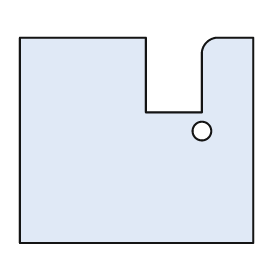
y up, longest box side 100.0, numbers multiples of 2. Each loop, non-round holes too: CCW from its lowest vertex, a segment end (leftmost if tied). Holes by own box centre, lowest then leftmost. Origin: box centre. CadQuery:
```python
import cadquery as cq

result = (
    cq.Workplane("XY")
    .moveTo(-50.0, -44.0)
    .lineTo(50.0, -44.0)
    .lineTo(50.0, 44.0)
    .lineTo(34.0, 44.0)
    .threePointArc((30.0, 42.0), (28.0, 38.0))
    .lineTo(28.0, 12.0)
    .lineTo(4.0, 12.0)
    .lineTo(4.0, 44.0)
    .lineTo(-50.0, 44.0)
    .close()
    .moveTo(28.0, 4.0)
    .circle(4.0)
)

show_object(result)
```